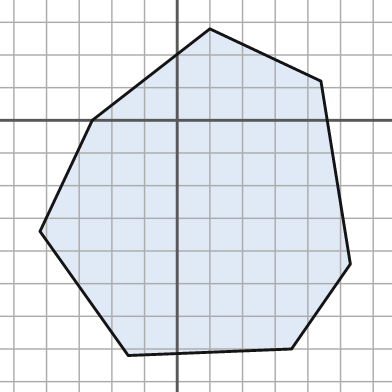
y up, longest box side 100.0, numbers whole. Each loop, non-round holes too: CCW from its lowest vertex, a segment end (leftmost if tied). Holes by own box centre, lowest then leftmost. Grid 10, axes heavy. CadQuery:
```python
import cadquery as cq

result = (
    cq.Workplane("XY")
    .moveTo(-15.0, -72.0)
    .lineTo(35.0, -70.0)
    .lineTo(53.0, -44.0)
    .lineTo(44.0, 12.0)
    .lineTo(10.0, 28.0)
    .lineTo(-26.0, 0.0)
    .lineTo(-42.0, -34.0)
    .close()
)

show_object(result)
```